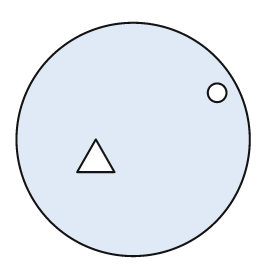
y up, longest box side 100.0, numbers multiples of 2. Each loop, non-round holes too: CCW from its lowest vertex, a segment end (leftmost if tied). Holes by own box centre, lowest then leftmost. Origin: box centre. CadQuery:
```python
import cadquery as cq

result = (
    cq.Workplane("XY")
    .moveTo(0.0, 0.0)
    .circle(50.0)
    .moveTo(-24.0, -14.0)
    .lineTo(-8.0, -14.0)
    .lineTo(-16.0, 0.0)
    .close()
    .moveTo(36.0, 20.0)
    .circle(4.0)
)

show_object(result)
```